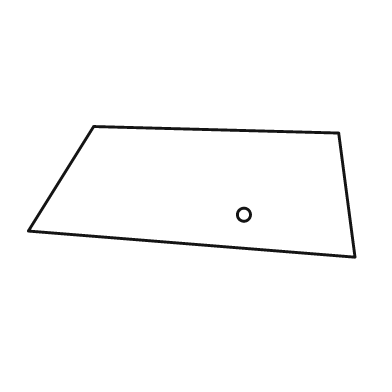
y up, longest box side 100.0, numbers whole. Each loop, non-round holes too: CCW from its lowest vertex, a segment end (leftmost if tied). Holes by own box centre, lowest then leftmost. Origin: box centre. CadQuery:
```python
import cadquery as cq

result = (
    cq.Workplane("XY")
    .moveTo(50.0, -20.0)
    .lineTo(45.0, 18.0)
    .lineTo(-30.0, 20.0)
    .lineTo(-50.0, -12.0)
    .close()
    .moveTo(16.0, -7.0)
    .circle(2.0)
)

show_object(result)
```